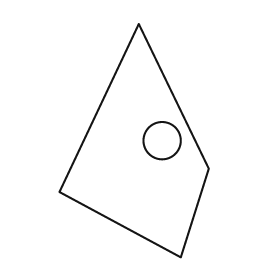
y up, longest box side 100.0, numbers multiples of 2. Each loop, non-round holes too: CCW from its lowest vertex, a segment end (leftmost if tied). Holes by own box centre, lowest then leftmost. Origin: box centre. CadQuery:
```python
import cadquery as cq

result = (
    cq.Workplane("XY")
    .moveTo(20.0, -50.0)
    .lineTo(32.0, -12.0)
    .lineTo(2.0, 50.0)
    .lineTo(-32.0, -22.0)
    .close()
    .moveTo(12.0, 0.0)
    .circle(8.0)
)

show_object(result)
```